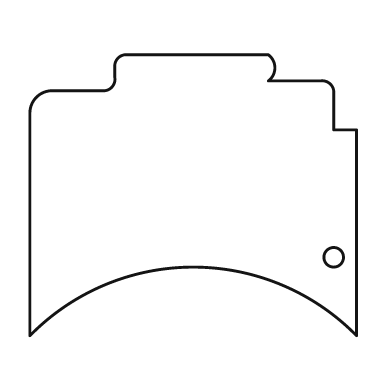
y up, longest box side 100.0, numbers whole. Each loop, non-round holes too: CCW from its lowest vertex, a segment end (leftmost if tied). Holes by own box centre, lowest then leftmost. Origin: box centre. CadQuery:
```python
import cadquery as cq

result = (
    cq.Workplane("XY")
    .moveTo(-50.0, -43.0)
    .threePointArc((0.0, -22.0), (50.0, -43.0))
    .lineTo(50.0, 20.0)
    .lineTo(43.0, 20.0)
    .lineTo(43.0, 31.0)
    .threePointArc((42.0, 34.0), (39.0, 35.0))
    .lineTo(23.0, 35.0)
    .threePointArc((25.0, 39.0), (23.0, 43.0))
    .lineTo(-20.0, 43.0)
    .threePointArc((-23.0, 42.0), (-24.0, 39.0))
    .lineTo(-24.0, 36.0)
    .threePointArc((-25.0, 33.0), (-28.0, 32.0))
    .lineTo(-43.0, 32.0)
    .threePointArc((-48.0, 30.0), (-50.0, 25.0))
    .close()
    .moveTo(43.0, -19.0)
    .circle(3.0)
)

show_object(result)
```